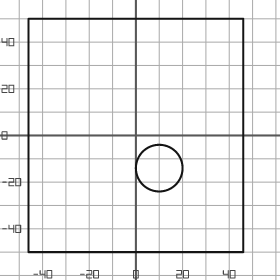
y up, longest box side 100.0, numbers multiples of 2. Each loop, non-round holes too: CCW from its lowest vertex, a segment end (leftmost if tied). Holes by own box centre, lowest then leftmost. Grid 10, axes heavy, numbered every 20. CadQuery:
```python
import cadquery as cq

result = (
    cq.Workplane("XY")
    .moveTo(-46.0, -50.0)
    .lineTo(46.0, -50.0)
    .lineTo(46.0, 50.0)
    .lineTo(-46.0, 50.0)
    .close()
    .moveTo(10.0, -14.0)
    .circle(10.0)
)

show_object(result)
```